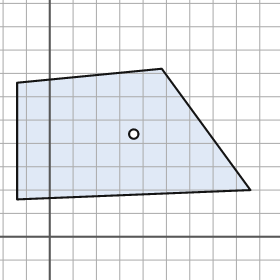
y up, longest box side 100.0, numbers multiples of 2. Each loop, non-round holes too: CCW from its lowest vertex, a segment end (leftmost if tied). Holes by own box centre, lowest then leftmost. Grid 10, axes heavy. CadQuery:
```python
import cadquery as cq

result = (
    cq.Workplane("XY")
    .moveTo(-14.0, 16.0)
    .lineTo(86.0, 20.0)
    .lineTo(48.0, 72.0)
    .lineTo(-14.0, 66.0)
    .close()
    .moveTo(36.0, 44.0)
    .circle(2.0)
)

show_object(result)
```